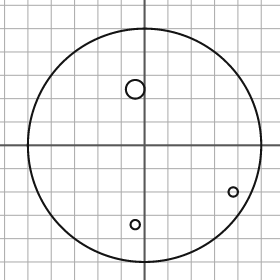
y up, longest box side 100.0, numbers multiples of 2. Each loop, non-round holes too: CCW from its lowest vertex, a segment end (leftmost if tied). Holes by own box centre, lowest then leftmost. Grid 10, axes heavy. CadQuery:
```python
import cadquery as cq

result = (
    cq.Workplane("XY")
    .moveTo(0.0, 0.0)
    .circle(50.0)
    .moveTo(-4.0, -34.0)
    .circle(2.0)
    .moveTo(38.0, -20.0)
    .circle(2.0)
    .moveTo(-4.0, 24.0)
    .circle(4.0)
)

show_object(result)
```